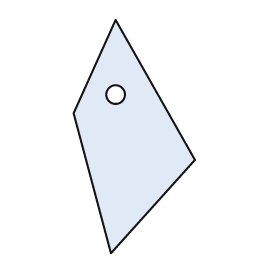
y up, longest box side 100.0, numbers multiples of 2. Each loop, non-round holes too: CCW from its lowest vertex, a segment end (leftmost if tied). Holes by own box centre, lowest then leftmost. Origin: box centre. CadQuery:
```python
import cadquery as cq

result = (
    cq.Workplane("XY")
    .moveTo(-10.0, -50.0)
    .lineTo(26.0, -10.0)
    .lineTo(-8.0, 50.0)
    .lineTo(-26.0, 10.0)
    .close()
    .moveTo(-8.0, 18.0)
    .circle(4.0)
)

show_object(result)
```